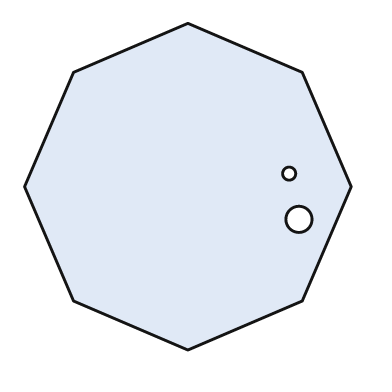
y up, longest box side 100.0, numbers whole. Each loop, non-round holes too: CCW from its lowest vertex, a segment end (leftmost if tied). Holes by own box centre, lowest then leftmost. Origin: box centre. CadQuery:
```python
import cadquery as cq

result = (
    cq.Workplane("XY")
    .moveTo(0.0, -50.0)
    .lineTo(35.0, -35.0)
    .lineTo(50.0, 0.0)
    .lineTo(35.0, 35.0)
    .lineTo(0.0, 50.0)
    .lineTo(-35.0, 35.0)
    .lineTo(-50.0, 0.0)
    .lineTo(-35.0, -35.0)
    .close()
    .moveTo(34.0, -10.0)
    .circle(4.0)
    .moveTo(31.0, 4.0)
    .circle(2.0)
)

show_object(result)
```